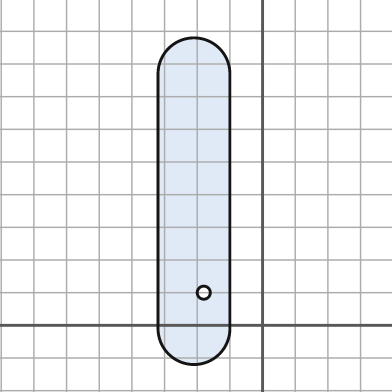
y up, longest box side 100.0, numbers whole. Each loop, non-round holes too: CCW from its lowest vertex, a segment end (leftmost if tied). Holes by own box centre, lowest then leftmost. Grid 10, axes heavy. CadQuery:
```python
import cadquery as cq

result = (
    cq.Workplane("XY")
    .moveTo(-32.0, -1.0)
    .threePointArc((-21.0, -12.0), (-10.0, -1.0))
    .lineTo(-10.0, 77.0)
    .threePointArc((-21.0, 88.0), (-32.0, 77.0))
    .close()
    .moveTo(-18.0, 10.0)
    .circle(2.0)
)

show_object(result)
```